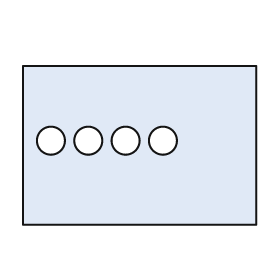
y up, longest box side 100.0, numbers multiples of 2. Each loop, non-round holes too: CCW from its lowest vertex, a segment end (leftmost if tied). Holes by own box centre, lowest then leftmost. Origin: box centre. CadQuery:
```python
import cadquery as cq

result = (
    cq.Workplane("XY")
    .moveTo(-50.0, -34.0)
    .lineTo(50.0, -34.0)
    .lineTo(50.0, 34.0)
    .lineTo(-50.0, 34.0)
    .close()
    .moveTo(-38.0, 2.0)
    .circle(6.0)
    .moveTo(-22.0, 2.0)
    .circle(6.0)
    .moveTo(-6.0, 2.0)
    .circle(6.0)
    .moveTo(10.0, 2.0)
    .circle(6.0)
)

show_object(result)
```